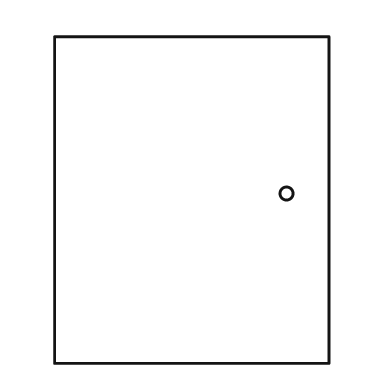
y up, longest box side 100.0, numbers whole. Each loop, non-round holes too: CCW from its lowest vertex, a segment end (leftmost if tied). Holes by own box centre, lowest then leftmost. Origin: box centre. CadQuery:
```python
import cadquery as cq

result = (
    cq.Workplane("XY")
    .moveTo(-42.0, -50.0)
    .lineTo(42.0, -50.0)
    .lineTo(42.0, 50.0)
    .lineTo(-42.0, 50.0)
    .close()
    .moveTo(29.0, 2.0)
    .circle(2.0)
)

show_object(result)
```